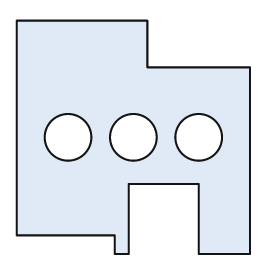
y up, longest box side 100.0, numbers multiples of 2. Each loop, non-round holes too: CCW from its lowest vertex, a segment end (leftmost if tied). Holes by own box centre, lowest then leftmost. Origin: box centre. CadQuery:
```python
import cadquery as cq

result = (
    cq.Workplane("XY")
    .moveTo(-8.0, -50.0)
    .lineTo(-2.0, -50.0)
    .lineTo(-2.0, -20.0)
    .lineTo(28.0, -20.0)
    .lineTo(28.0, -50.0)
    .lineTo(50.0, -50.0)
    .lineTo(50.0, 30.0)
    .lineTo(6.0, 30.0)
    .lineTo(6.0, 50.0)
    .lineTo(-50.0, 50.0)
    .lineTo(-50.0, -42.0)
    .lineTo(-8.0, -42.0)
    .close()
    .moveTo(-28.0, 0.0)
    .circle(10.0)
    .moveTo(0.0, 0.0)
    .circle(10.0)
    .moveTo(28.0, 0.0)
    .circle(10.0)
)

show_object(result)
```